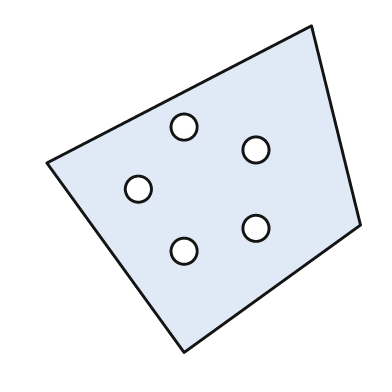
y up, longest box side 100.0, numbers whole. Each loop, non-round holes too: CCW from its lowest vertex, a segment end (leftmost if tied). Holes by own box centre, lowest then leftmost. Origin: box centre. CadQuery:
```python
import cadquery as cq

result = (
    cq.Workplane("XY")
    .moveTo(-6.0, -50.0)
    .lineTo(48.0, -11.0)
    .lineTo(33.0, 50.0)
    .lineTo(-48.0, 8.0)
    .close()
    .moveTo(-6.0, -19.0)
    .circle(4.0)
    .moveTo(16.0, -12.0)
    .circle(4.0)
    .moveTo(-20.0, 0.0)
    .circle(4.0)
    .moveTo(16.0, 12.0)
    .circle(4.0)
    .moveTo(-6.0, 19.0)
    .circle(4.0)
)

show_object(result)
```